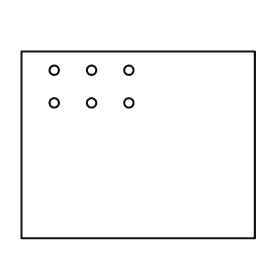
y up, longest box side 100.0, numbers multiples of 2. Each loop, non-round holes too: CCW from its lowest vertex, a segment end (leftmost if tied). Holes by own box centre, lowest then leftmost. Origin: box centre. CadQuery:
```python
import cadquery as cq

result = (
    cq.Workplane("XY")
    .moveTo(-50.0, -40.0)
    .lineTo(50.0, -40.0)
    .lineTo(50.0, 40.0)
    .lineTo(-50.0, 40.0)
    .close()
    .moveTo(-36.0, 18.0)
    .circle(2.0)
    .moveTo(-20.0, 18.0)
    .circle(2.0)
    .moveTo(-4.0, 18.0)
    .circle(2.0)
    .moveTo(-36.0, 32.0)
    .circle(2.0)
    .moveTo(-20.0, 32.0)
    .circle(2.0)
    .moveTo(-4.0, 32.0)
    .circle(2.0)
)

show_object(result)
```